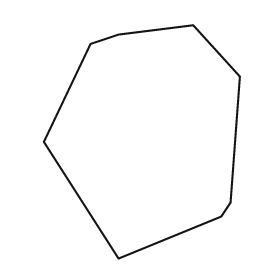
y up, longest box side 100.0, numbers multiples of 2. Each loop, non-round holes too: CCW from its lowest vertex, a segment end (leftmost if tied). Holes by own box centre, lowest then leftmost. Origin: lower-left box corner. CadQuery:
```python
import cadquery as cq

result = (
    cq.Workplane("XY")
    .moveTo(32.0, 0.0)
    .lineTo(76.0, 18.0)
    .lineTo(80.0, 24.0)
    .lineTo(84.0, 78.0)
    .lineTo(64.0, 100.0)
    .lineTo(32.0, 96.0)
    .lineTo(20.0, 92.0)
    .lineTo(0.0, 50.0)
    .close()
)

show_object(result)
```